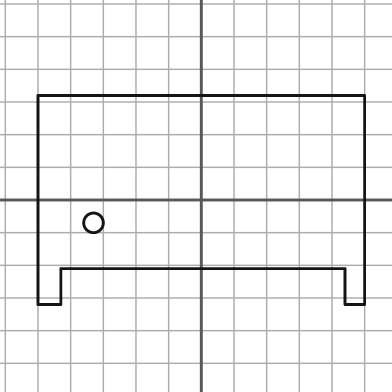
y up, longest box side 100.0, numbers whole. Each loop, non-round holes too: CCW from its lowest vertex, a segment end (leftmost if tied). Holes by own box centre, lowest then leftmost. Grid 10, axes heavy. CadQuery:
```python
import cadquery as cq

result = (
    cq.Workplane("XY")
    .moveTo(-50.0, -32.0)
    .lineTo(-43.0, -32.0)
    .lineTo(-43.0, -21.0)
    .lineTo(44.0, -21.0)
    .lineTo(44.0, -32.0)
    .lineTo(50.0, -32.0)
    .lineTo(50.0, 32.0)
    .lineTo(-50.0, 32.0)
    .close()
    .moveTo(-33.0, -7.0)
    .circle(3.0)
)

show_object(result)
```